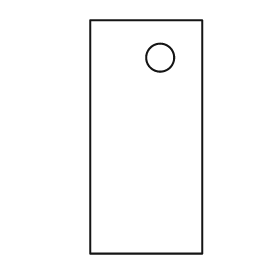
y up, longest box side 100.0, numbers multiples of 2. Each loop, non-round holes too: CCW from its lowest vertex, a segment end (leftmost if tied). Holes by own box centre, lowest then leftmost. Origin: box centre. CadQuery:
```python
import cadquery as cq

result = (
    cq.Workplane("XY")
    .moveTo(-24.0, -50.0)
    .lineTo(24.0, -50.0)
    .lineTo(24.0, 50.0)
    .lineTo(-24.0, 50.0)
    .close()
    .moveTo(6.0, 34.0)
    .circle(6.0)
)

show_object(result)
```